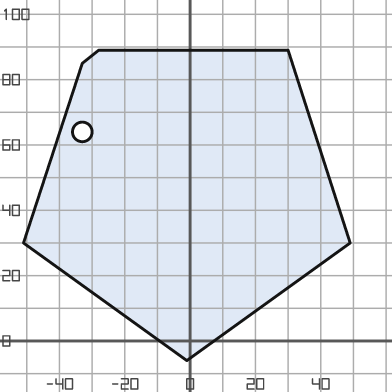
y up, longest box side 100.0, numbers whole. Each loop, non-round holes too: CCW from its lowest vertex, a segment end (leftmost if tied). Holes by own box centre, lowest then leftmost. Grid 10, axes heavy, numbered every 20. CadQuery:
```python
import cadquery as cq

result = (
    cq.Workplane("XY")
    .moveTo(-1.0, -6.0)
    .lineTo(49.0, 30.0)
    .lineTo(30.0, 89.0)
    .lineTo(-28.0, 89.0)
    .lineTo(-33.0, 85.0)
    .lineTo(-51.0, 30.0)
    .close()
    .moveTo(-33.0, 64.0)
    .circle(3.0)
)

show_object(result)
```